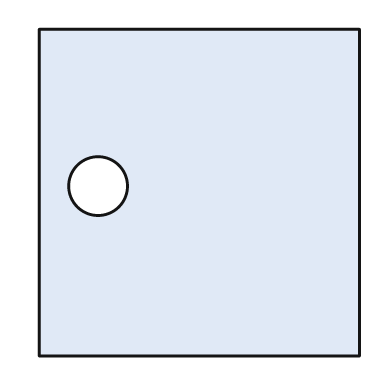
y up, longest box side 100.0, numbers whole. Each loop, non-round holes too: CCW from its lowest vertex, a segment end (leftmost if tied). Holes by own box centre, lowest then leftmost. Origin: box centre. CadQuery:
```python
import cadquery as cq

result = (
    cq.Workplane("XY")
    .moveTo(-49.0, -50.0)
    .lineTo(49.0, -50.0)
    .lineTo(49.0, 50.0)
    .lineTo(-49.0, 50.0)
    .close()
    .moveTo(-31.0, 2.0)
    .circle(9.0)
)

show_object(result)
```